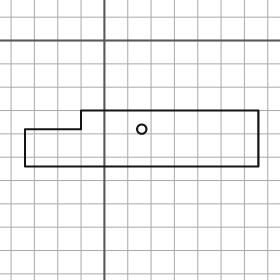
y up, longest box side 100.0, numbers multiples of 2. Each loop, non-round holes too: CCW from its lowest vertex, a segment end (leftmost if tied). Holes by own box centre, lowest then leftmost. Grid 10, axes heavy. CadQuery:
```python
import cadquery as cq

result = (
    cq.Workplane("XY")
    .moveTo(-34.0, -54.0)
    .lineTo(66.0, -54.0)
    .lineTo(66.0, -30.0)
    .lineTo(-10.0, -30.0)
    .lineTo(-10.0, -38.0)
    .lineTo(-34.0, -38.0)
    .close()
    .moveTo(16.0, -38.0)
    .circle(2.0)
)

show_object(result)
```